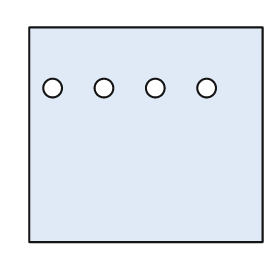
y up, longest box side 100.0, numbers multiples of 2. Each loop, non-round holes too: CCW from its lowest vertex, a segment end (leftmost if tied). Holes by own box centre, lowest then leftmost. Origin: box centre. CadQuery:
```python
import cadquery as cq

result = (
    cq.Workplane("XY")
    .moveTo(-50.0, -46.0)
    .lineTo(50.0, -46.0)
    .lineTo(50.0, 46.0)
    .lineTo(-50.0, 46.0)
    .close()
    .moveTo(-40.0, 20.0)
    .circle(4.0)
    .moveTo(-18.0, 20.0)
    .circle(4.0)
    .moveTo(4.0, 20.0)
    .circle(4.0)
    .moveTo(26.0, 20.0)
    .circle(4.0)
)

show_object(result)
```